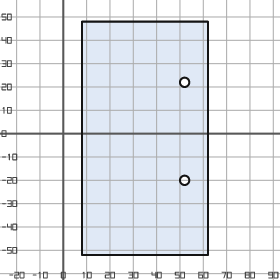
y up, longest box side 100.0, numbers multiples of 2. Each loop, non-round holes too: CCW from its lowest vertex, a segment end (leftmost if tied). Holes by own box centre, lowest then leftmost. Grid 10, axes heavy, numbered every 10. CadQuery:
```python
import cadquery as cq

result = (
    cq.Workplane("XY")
    .moveTo(8.0, -52.0)
    .lineTo(62.0, -52.0)
    .lineTo(62.0, 48.0)
    .lineTo(8.0, 48.0)
    .close()
    .moveTo(52.0, -20.0)
    .circle(2.0)
    .moveTo(52.0, 22.0)
    .circle(2.0)
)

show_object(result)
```